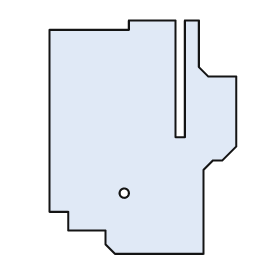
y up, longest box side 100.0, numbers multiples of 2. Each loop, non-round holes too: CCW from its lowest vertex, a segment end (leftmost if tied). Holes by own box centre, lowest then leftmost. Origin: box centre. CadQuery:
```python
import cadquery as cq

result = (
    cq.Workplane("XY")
    .moveTo(-12.0, -50.0)
    .lineTo(26.0, -50.0)
    .lineTo(26.0, -14.0)
    .lineTo(30.0, -10.0)
    .lineTo(34.0, -10.0)
    .lineTo(40.0, -4.0)
    .lineTo(40.0, 26.0)
    .lineTo(28.0, 26.0)
    .lineTo(24.0, 30.0)
    .lineTo(24.0, 50.0)
    .lineTo(18.0, 50.0)
    .lineTo(18.0, 0.0)
    .lineTo(14.0, 0.0)
    .lineTo(14.0, 50.0)
    .lineTo(-6.0, 50.0)
    .lineTo(-6.0, 46.0)
    .lineTo(-40.0, 46.0)
    .lineTo(-40.0, -32.0)
    .lineTo(-32.0, -32.0)
    .lineTo(-32.0, -40.0)
    .lineTo(-16.0, -40.0)
    .lineTo(-16.0, -46.0)
    .close()
    .moveTo(-8.0, -24.0)
    .circle(2.0)
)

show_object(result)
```